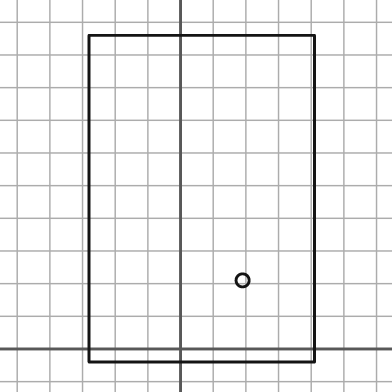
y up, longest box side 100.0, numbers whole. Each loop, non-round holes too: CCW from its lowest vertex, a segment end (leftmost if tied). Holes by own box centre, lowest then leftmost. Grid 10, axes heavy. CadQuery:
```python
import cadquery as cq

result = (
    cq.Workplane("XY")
    .moveTo(-28.0, -4.0)
    .lineTo(41.0, -4.0)
    .lineTo(41.0, 96.0)
    .lineTo(-28.0, 96.0)
    .close()
    .moveTo(19.0, 21.0)
    .circle(2.0)
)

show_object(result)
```